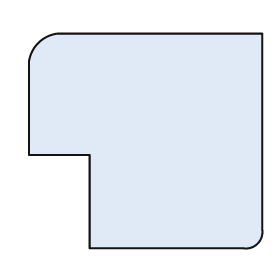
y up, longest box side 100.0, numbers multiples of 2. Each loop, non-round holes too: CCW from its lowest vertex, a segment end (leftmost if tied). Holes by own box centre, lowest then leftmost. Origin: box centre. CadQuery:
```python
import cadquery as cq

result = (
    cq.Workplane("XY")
    .moveTo(-24.0, -46.0)
    .lineTo(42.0, -46.0)
    .threePointArc((48.0, -44.0), (50.0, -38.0))
    .lineTo(50.0, 46.0)
    .lineTo(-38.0, 46.0)
    .threePointArc((-46.0, 42.0), (-50.0, 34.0))
    .lineTo(-50.0, -6.0)
    .lineTo(-24.0, -6.0)
    .close()
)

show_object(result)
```